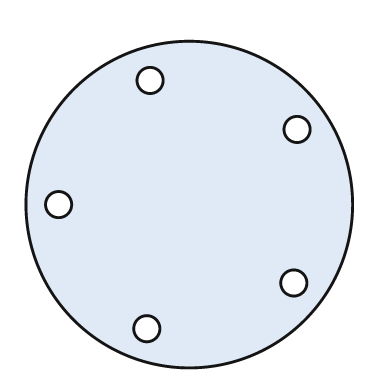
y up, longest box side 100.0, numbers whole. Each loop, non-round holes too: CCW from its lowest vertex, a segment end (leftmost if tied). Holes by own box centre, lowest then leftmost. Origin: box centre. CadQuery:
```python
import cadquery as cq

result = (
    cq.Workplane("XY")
    .moveTo(0.0, 0.0)
    .circle(50.0)
    .moveTo(-13.0, -38.0)
    .circle(4.0)
    .moveTo(32.0, -24.0)
    .circle(4.0)
    .moveTo(-40.0, 0.0)
    .circle(4.0)
    .moveTo(33.0, 23.0)
    .circle(4.0)
    .moveTo(-12.0, 38.0)
    .circle(4.0)
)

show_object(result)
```